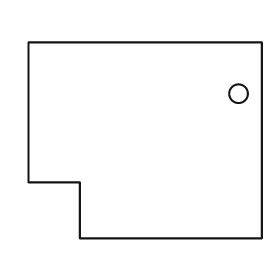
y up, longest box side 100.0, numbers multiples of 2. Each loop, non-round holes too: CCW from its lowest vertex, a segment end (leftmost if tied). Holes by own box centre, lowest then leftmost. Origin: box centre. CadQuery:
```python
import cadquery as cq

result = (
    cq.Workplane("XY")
    .moveTo(-28.0, -42.0)
    .lineTo(50.0, -42.0)
    .lineTo(50.0, 42.0)
    .lineTo(-50.0, 42.0)
    .lineTo(-50.0, -18.0)
    .lineTo(-28.0, -18.0)
    .close()
    .moveTo(40.0, 20.0)
    .circle(4.0)
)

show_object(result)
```